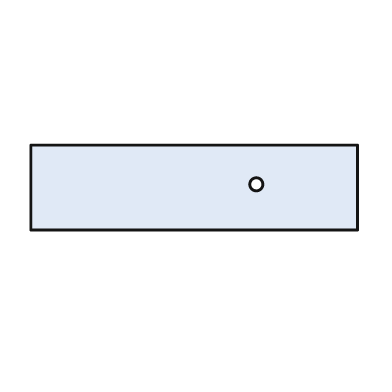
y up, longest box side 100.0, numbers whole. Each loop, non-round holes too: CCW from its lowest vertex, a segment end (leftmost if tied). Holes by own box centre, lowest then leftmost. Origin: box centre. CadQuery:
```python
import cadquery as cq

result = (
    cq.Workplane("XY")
    .moveTo(-50.0, -13.0)
    .lineTo(50.0, -13.0)
    .lineTo(50.0, 13.0)
    .lineTo(-50.0, 13.0)
    .close()
    .moveTo(19.0, 1.0)
    .circle(2.0)
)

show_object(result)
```